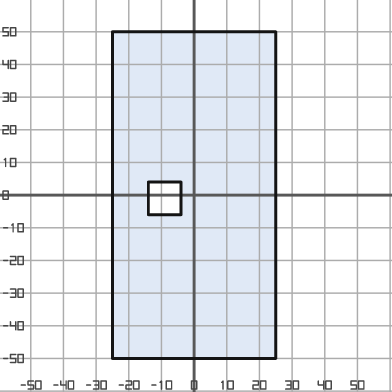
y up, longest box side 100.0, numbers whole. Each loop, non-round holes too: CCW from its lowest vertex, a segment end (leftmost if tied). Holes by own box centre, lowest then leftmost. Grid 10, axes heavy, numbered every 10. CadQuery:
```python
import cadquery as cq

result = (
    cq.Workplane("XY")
    .moveTo(-25.0, -50.0)
    .lineTo(25.0, -50.0)
    .lineTo(25.0, 50.0)
    .lineTo(-25.0, 50.0)
    .close()
    .moveTo(-14.0, -6.0)
    .lineTo(-4.0, -6.0)
    .lineTo(-4.0, 4.0)
    .lineTo(-14.0, 4.0)
    .close()
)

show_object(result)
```